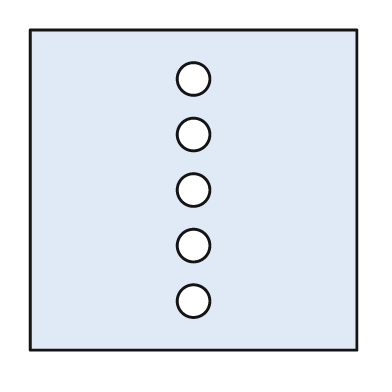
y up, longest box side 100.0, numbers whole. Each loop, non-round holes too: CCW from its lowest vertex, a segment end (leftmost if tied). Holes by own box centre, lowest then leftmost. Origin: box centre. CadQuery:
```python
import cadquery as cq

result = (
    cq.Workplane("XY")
    .moveTo(-50.0, -49.0)
    .lineTo(50.0, -49.0)
    .lineTo(50.0, 49.0)
    .lineTo(-50.0, 49.0)
    .close()
    .moveTo(0.0, -34.0)
    .circle(5.0)
    .moveTo(0.0, -17.0)
    .circle(5.0)
    .moveTo(0.0, 0.0)
    .circle(5.0)
    .moveTo(0.0, 17.0)
    .circle(5.0)
    .moveTo(0.0, 34.0)
    .circle(5.0)
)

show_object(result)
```